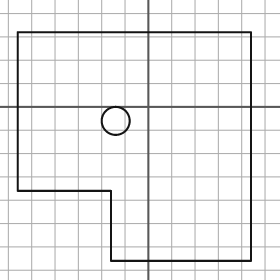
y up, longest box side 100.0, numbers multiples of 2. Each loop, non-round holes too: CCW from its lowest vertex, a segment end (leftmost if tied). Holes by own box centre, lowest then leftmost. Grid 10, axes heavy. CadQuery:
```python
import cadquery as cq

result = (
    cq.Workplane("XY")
    .moveTo(-16.0, -66.0)
    .lineTo(44.0, -66.0)
    .lineTo(44.0, 32.0)
    .lineTo(-56.0, 32.0)
    .lineTo(-56.0, -36.0)
    .lineTo(-16.0, -36.0)
    .close()
    .moveTo(-14.0, -6.0)
    .circle(6.0)
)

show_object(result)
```